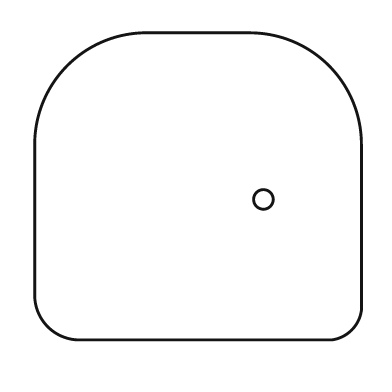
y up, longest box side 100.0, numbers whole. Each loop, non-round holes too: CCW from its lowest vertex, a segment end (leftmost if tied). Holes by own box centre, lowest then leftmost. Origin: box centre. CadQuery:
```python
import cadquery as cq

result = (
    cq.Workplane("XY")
    .moveTo(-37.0, -47.0)
    .lineTo(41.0, -47.0)
    .threePointArc((47.0, -44.0), (50.0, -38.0))
    .lineTo(50.0, 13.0)
    .threePointArc((40.0, 37.0), (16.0, 47.0))
    .lineTo(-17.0, 47.0)
    .threePointArc((-40.0, 37.0), (-50.0, 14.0))
    .lineTo(-50.0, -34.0)
    .threePointArc((-46.0, -43.0), (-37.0, -47.0))
    .close()
    .moveTo(20.0, -4.0)
    .circle(3.0)
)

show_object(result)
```